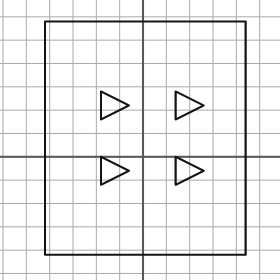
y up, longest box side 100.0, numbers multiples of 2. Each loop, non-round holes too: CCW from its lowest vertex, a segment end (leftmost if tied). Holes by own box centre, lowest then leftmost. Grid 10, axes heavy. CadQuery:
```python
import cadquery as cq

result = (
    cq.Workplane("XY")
    .moveTo(-42.0, -42.0)
    .lineTo(44.0, -42.0)
    .lineTo(44.0, 58.0)
    .lineTo(-42.0, 58.0)
    .close()
    .moveTo(-18.0, -12.0)
    .lineTo(-6.0, -6.0)
    .lineTo(-18.0, 0.0)
    .close()
    .moveTo(14.0, -12.0)
    .lineTo(26.0, -6.0)
    .lineTo(14.0, 0.0)
    .close()
    .moveTo(-18.0, 16.0)
    .lineTo(-6.0, 22.0)
    .lineTo(-18.0, 28.0)
    .close()
    .moveTo(14.0, 16.0)
    .lineTo(26.0, 22.0)
    .lineTo(14.0, 28.0)
    .close()
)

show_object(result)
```